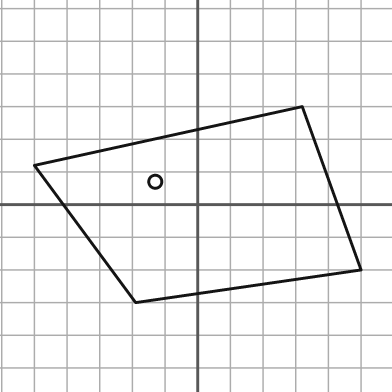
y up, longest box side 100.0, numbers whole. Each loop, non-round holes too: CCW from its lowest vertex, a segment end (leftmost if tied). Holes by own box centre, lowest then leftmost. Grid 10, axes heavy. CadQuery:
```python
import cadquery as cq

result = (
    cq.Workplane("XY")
    .moveTo(-19.0, -30.0)
    .lineTo(50.0, -20.0)
    .lineTo(32.0, 30.0)
    .lineTo(-50.0, 12.0)
    .close()
    .moveTo(-13.0, 7.0)
    .circle(2.0)
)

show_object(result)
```